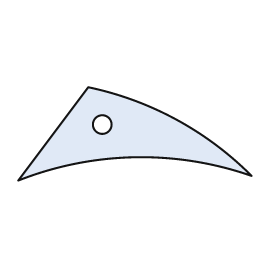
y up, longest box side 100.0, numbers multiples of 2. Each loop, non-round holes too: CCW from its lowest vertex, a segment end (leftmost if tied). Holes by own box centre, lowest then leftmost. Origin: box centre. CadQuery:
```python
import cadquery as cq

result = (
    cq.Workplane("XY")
    .moveTo(-50.0, -20.0)
    .threePointArc((0.0, -10.0), (50.0, -18.0))
    .threePointArc((18.0, 6.0), (-20.0, 20.0))
    .close()
    .moveTo(-14.0, 4.0)
    .circle(4.0)
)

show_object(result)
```